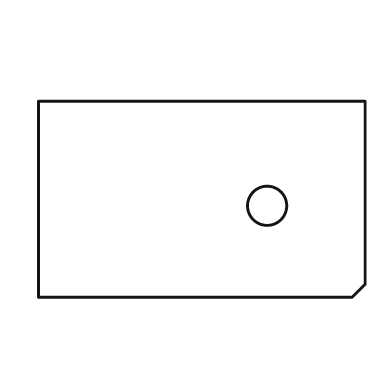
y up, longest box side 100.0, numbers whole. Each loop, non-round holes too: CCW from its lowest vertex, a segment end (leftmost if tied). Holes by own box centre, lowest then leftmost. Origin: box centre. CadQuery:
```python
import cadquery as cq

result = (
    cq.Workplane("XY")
    .moveTo(-50.0, -30.0)
    .lineTo(46.0, -30.0)
    .lineTo(50.0, -26.0)
    .lineTo(50.0, 30.0)
    .lineTo(-50.0, 30.0)
    .close()
    .moveTo(20.0, -2.0)
    .circle(6.0)
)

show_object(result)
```